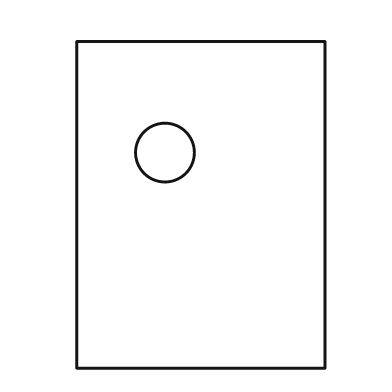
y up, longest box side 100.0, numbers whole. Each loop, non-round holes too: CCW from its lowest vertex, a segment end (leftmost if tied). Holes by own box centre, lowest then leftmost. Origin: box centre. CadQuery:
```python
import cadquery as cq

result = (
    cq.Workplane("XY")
    .moveTo(-38.0, -50.0)
    .lineTo(38.0, -50.0)
    .lineTo(38.0, 50.0)
    .lineTo(-38.0, 50.0)
    .close()
    .moveTo(-11.0, 16.0)
    .circle(9.0)
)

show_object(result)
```